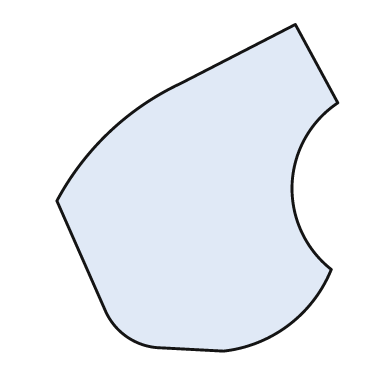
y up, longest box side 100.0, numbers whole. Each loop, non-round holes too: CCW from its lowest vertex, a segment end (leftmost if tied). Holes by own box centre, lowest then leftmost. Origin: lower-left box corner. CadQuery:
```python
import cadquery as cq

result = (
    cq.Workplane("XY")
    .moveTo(51.0, 0.0)
    .threePointArc((71.0, 8.0), (84.0, 25.0))
    .threePointArc((72.0, 51.0), (86.0, 76.0))
    .lineTo(73.0, 100.0)
    .lineTo(38.0, 82.0)
    .threePointArc((16.0, 67.0), (0.0, 46.0))
    .lineTo(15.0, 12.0)
    .threePointArc((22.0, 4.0), (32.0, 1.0))
    .close()
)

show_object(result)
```